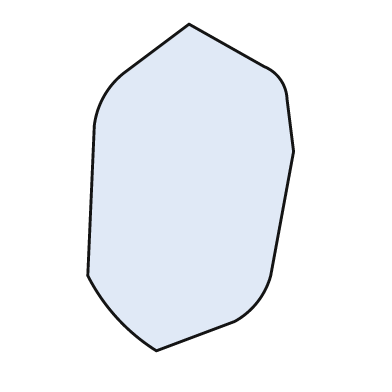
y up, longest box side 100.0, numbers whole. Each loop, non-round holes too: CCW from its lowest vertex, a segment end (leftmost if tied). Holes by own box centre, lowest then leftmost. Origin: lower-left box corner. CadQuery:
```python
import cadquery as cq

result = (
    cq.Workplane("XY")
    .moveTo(21.0, 0.0)
    .lineTo(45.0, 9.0)
    .threePointArc((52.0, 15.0), (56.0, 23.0))
    .lineTo(63.0, 61.0)
    .lineTo(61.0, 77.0)
    .threePointArc((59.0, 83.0), (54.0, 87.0))
    .lineTo(31.0, 100.0)
    .lineTo(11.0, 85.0)
    .threePointArc((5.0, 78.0), (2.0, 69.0))
    .lineTo(0.0, 23.0)
    .threePointArc((9.0, 10.0), (21.0, 0.0))
    .close()
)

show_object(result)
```